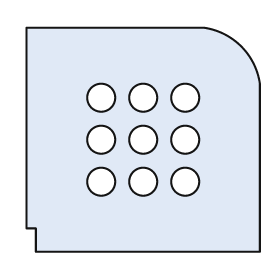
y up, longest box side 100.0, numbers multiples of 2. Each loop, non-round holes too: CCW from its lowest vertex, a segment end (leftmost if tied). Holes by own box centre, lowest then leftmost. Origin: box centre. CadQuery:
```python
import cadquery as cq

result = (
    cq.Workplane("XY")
    .moveTo(-46.0, -48.0)
    .lineTo(50.0, -48.0)
    .lineTo(50.0, 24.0)
    .threePointArc((42.0, 40.0), (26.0, 48.0))
    .lineTo(-50.0, 48.0)
    .lineTo(-50.0, -38.0)
    .lineTo(-46.0, -38.0)
    .close()
    .moveTo(-18.0, -18.0)
    .circle(6.0)
    .moveTo(0.0, -18.0)
    .circle(6.0)
    .moveTo(18.0, -18.0)
    .circle(6.0)
    .moveTo(-18.0, 0.0)
    .circle(6.0)
    .moveTo(0.0, 0.0)
    .circle(6.0)
    .moveTo(18.0, 0.0)
    .circle(6.0)
    .moveTo(-18.0, 18.0)
    .circle(6.0)
    .moveTo(0.0, 18.0)
    .circle(6.0)
    .moveTo(18.0, 18.0)
    .circle(6.0)
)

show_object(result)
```